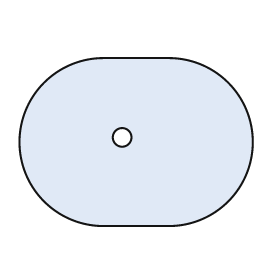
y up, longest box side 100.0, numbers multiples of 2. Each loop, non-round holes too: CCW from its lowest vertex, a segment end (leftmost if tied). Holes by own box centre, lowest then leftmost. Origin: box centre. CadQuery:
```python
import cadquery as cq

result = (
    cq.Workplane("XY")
    .moveTo(-14.0, -36.0)
    .lineTo(14.0, -36.0)
    .threePointArc((50.0, 0.0), (14.0, 36.0))
    .lineTo(-14.0, 36.0)
    .threePointArc((-50.0, 0.0), (-14.0, -36.0))
    .close()
    .moveTo(-6.0, 2.0)
    .circle(4.0)
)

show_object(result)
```